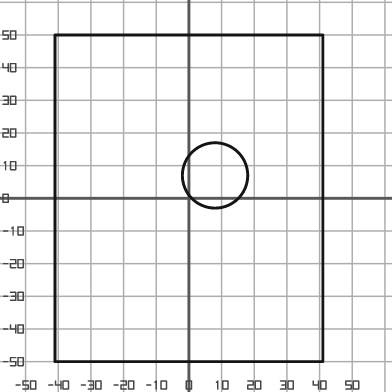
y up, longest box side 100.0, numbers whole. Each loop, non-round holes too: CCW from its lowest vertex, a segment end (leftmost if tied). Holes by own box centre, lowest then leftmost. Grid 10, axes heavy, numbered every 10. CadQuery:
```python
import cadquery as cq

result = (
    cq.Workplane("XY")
    .moveTo(-41.0, -50.0)
    .lineTo(41.0, -50.0)
    .lineTo(41.0, 50.0)
    .lineTo(-41.0, 50.0)
    .close()
    .moveTo(8.0, 7.0)
    .circle(10.0)
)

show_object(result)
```